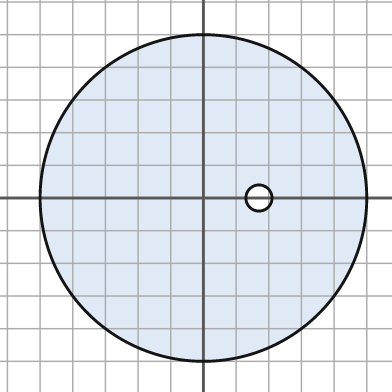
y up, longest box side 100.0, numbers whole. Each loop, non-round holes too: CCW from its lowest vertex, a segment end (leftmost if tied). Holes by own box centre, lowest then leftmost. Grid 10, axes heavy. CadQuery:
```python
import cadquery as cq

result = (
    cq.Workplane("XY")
    .moveTo(0.0, 0.0)
    .circle(50.0)
    .moveTo(17.0, 0.0)
    .circle(4.0)
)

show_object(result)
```